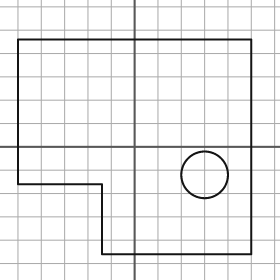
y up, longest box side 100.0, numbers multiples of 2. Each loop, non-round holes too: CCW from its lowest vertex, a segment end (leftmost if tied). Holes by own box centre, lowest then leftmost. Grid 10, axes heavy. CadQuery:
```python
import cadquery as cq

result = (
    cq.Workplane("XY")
    .moveTo(-14.0, -46.0)
    .lineTo(50.0, -46.0)
    .lineTo(50.0, 46.0)
    .lineTo(-50.0, 46.0)
    .lineTo(-50.0, -16.0)
    .lineTo(-14.0, -16.0)
    .close()
    .moveTo(30.0, -12.0)
    .circle(10.0)
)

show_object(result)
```